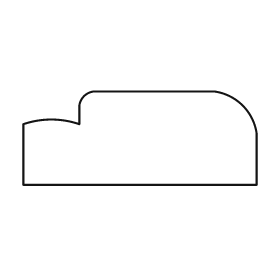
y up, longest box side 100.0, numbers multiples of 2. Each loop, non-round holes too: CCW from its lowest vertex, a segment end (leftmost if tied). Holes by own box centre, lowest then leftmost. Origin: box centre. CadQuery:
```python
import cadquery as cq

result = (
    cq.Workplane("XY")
    .moveTo(-50.0, -20.0)
    .lineTo(50.0, -20.0)
    .lineTo(50.0, 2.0)
    .threePointArc((44.0, 14.0), (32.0, 20.0))
    .lineTo(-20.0, 20.0)
    .threePointArc((-24.0, 18.0), (-26.0, 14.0))
    .lineTo(-26.0, 6.0)
    .threePointArc((-38.0, 8.0), (-50.0, 6.0))
    .close()
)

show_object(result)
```